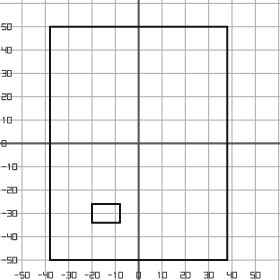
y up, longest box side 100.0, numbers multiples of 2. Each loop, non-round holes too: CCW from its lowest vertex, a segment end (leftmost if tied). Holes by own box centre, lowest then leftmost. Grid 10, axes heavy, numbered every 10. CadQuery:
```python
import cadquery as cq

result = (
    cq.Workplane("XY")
    .moveTo(-38.0, -50.0)
    .lineTo(38.0, -50.0)
    .lineTo(38.0, 50.0)
    .lineTo(-38.0, 50.0)
    .close()
    .moveTo(-20.0, -34.0)
    .lineTo(-8.0, -34.0)
    .lineTo(-8.0, -26.0)
    .lineTo(-20.0, -26.0)
    .close()
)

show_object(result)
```